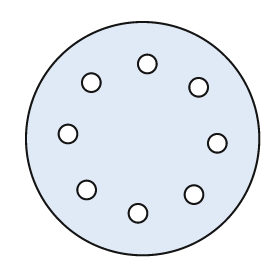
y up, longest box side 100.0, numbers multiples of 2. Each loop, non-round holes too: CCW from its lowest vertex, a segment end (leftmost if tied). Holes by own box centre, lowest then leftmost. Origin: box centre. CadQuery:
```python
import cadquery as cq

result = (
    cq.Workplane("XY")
    .moveTo(0.0, 0.0)
    .circle(50.0)
    .moveTo(-2.0, -32.0)
    .circle(4.0)
    .moveTo(22.0, -24.0)
    .circle(4.0)
    .moveTo(-24.0, -22.0)
    .circle(4.0)
    .moveTo(32.0, -2.0)
    .circle(4.0)
    .moveTo(-32.0, 2.0)
    .circle(4.0)
    .moveTo(24.0, 22.0)
    .circle(4.0)
    .moveTo(-22.0, 24.0)
    .circle(4.0)
    .moveTo(2.0, 32.0)
    .circle(4.0)
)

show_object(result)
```